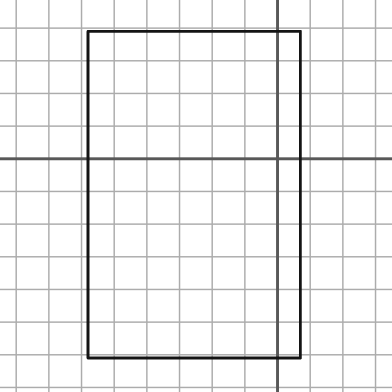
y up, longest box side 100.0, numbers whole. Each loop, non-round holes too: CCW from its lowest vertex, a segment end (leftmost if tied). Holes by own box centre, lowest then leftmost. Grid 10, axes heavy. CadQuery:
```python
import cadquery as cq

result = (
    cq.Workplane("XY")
    .moveTo(-58.0, -61.0)
    .lineTo(7.0, -61.0)
    .lineTo(7.0, 39.0)
    .lineTo(-58.0, 39.0)
    .close()
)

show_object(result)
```